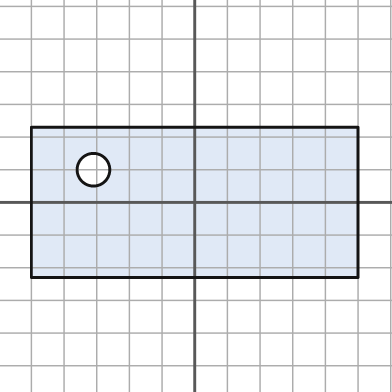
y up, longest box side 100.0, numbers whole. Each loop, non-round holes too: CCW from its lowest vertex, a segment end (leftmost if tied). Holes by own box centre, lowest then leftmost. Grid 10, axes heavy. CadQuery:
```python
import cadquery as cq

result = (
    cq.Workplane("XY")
    .moveTo(-50.0, -23.0)
    .lineTo(50.0, -23.0)
    .lineTo(50.0, 23.0)
    .lineTo(-50.0, 23.0)
    .close()
    .moveTo(-31.0, 10.0)
    .circle(5.0)
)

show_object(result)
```